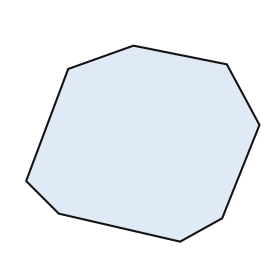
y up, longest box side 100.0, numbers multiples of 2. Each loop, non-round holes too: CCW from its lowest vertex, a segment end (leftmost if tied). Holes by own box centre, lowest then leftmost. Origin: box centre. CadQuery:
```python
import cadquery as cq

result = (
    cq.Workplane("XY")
    .moveTo(16.0, -42.0)
    .lineTo(34.0, -32.0)
    .lineTo(50.0, 8.0)
    .lineTo(36.0, 34.0)
    .lineTo(-4.0, 42.0)
    .lineTo(-32.0, 32.0)
    .lineTo(-50.0, -16.0)
    .lineTo(-36.0, -30.0)
    .close()
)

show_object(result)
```